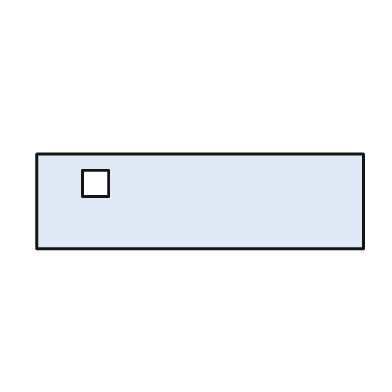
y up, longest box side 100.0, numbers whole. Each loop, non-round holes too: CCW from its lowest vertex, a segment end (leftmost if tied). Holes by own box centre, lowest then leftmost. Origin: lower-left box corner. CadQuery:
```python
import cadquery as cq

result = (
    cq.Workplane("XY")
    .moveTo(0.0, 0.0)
    .lineTo(100.0, 0.0)
    .lineTo(100.0, 29.0)
    .lineTo(0.0, 29.0)
    .close()
    .moveTo(14.0, 16.0)
    .lineTo(22.0, 16.0)
    .lineTo(22.0, 24.0)
    .lineTo(14.0, 24.0)
    .close()
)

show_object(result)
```